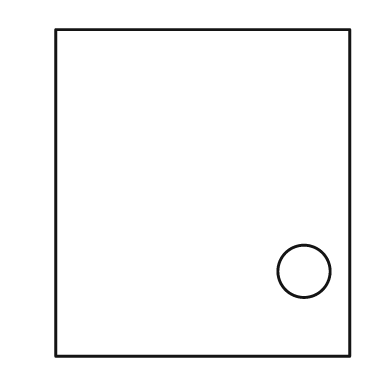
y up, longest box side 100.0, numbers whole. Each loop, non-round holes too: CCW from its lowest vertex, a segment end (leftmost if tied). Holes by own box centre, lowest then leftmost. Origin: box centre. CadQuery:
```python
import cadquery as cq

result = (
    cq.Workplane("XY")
    .moveTo(-45.0, -50.0)
    .lineTo(45.0, -50.0)
    .lineTo(45.0, 50.0)
    .lineTo(-45.0, 50.0)
    .close()
    .moveTo(31.0, -24.0)
    .circle(8.0)
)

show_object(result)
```